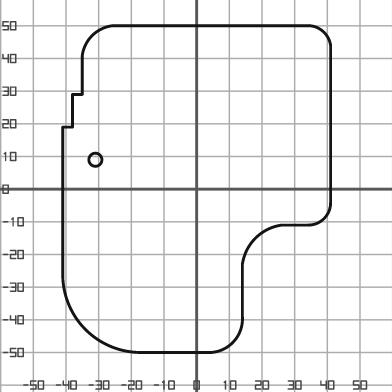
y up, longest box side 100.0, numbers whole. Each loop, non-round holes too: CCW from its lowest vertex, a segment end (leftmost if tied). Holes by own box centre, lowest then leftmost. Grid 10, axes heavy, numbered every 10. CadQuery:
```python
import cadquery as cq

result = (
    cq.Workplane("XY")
    .moveTo(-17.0, -50.0)
    .lineTo(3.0, -50.0)
    .threePointArc((11.0, -47.0), (14.0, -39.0))
    .lineTo(14.0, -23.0)
    .threePointArc((18.0, -15.0), (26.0, -11.0))
    .lineTo(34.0, -11.0)
    .threePointArc((39.0, -9.0), (41.0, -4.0))
    .lineTo(41.0, 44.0)
    .threePointArc((39.0, 48.0), (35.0, 50.0))
    .lineTo(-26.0, 50.0)
    .threePointArc((-32.0, 47.0), (-35.0, 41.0))
    .lineTo(-35.0, 29.0)
    .lineTo(-38.0, 29.0)
    .lineTo(-38.0, 19.0)
    .lineTo(-41.0, 19.0)
    .lineTo(-41.0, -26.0)
    .threePointArc((-34.0, -43.0), (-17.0, -50.0))
    .close()
    .moveTo(-31.0, 9.0)
    .circle(2.0)
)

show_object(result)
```